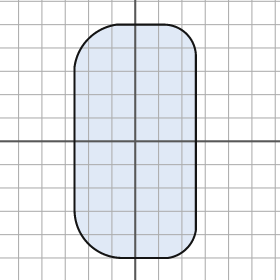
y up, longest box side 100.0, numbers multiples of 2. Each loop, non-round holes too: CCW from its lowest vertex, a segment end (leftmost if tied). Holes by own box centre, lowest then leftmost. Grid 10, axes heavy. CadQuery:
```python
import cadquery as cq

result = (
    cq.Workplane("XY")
    .moveTo(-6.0, -50.0)
    .lineTo(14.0, -50.0)
    .threePointArc((22.0, -46.0), (26.0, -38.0))
    .lineTo(26.0, 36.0)
    .threePointArc((22.0, 46.0), (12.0, 50.0))
    .lineTo(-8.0, 50.0)
    .threePointArc((-20.0, 44.0), (-26.0, 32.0))
    .lineTo(-26.0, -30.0)
    .threePointArc((-20.0, -44.0), (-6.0, -50.0))
    .close()
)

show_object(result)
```